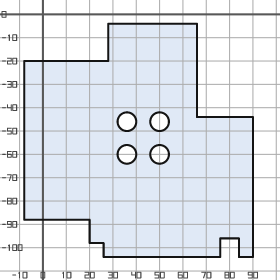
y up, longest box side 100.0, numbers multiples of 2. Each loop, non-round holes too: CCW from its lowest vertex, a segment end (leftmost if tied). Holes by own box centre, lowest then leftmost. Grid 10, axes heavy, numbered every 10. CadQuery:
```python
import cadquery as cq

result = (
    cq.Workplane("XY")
    .moveTo(26.0, -104.0)
    .lineTo(76.0, -104.0)
    .lineTo(76.0, -96.0)
    .lineTo(84.0, -96.0)
    .lineTo(84.0, -104.0)
    .lineTo(90.0, -104.0)
    .lineTo(90.0, -44.0)
    .lineTo(66.0, -44.0)
    .lineTo(66.0, -4.0)
    .lineTo(28.0, -4.0)
    .lineTo(28.0, -20.0)
    .lineTo(-8.0, -20.0)
    .lineTo(-8.0, -88.0)
    .lineTo(20.0, -88.0)
    .lineTo(20.0, -98.0)
    .lineTo(26.0, -98.0)
    .close()
    .moveTo(36.0, -60.0)
    .circle(4.0)
    .moveTo(50.0, -60.0)
    .circle(4.0)
    .moveTo(36.0, -46.0)
    .circle(4.0)
    .moveTo(50.0, -46.0)
    .circle(4.0)
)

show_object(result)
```